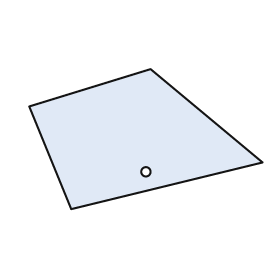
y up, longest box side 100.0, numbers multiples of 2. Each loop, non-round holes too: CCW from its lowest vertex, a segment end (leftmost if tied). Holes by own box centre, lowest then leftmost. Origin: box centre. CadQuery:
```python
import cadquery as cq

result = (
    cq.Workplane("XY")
    .moveTo(-32.0, -30.0)
    .lineTo(50.0, -10.0)
    .lineTo(2.0, 30.0)
    .lineTo(-50.0, 14.0)
    .close()
    .moveTo(0.0, -14.0)
    .circle(2.0)
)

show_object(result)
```